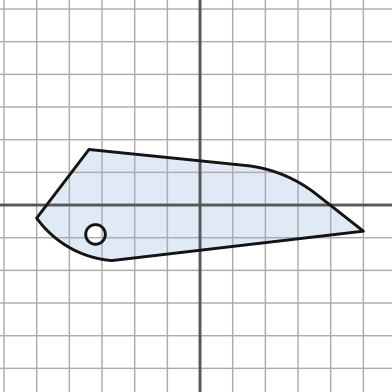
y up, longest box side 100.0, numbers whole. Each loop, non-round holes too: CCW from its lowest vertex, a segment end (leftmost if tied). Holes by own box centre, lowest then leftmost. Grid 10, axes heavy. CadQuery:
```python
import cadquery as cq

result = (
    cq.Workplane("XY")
    .moveTo(-27.0, -17.0)
    .lineTo(50.0, -8.0)
    .lineTo(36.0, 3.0)
    .threePointArc((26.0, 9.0), (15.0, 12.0))
    .lineTo(-34.0, 17.0)
    .lineTo(-50.0, -4.0)
    .threePointArc((-40.0, -13.0), (-27.0, -17.0))
    .close()
    .moveTo(-32.0, -9.0)
    .circle(3.0)
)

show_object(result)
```